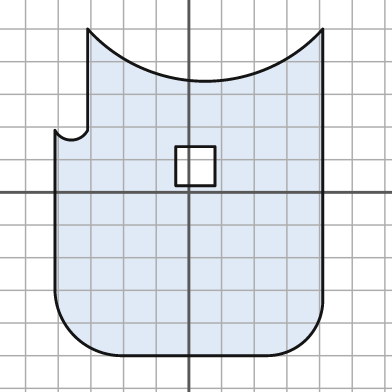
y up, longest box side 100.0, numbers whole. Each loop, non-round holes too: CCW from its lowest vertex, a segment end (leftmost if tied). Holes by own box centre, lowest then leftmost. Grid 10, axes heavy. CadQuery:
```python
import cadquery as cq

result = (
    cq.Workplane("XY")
    .moveTo(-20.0, -50.0)
    .lineTo(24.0, -50.0)
    .threePointArc((36.0, -45.0), (41.0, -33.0))
    .lineTo(41.0, 50.0)
    .threePointArc((5.0, 34.0), (-31.0, 50.0))
    .lineTo(-31.0, 19.0)
    .threePointArc((-36.0, 16.0), (-41.0, 19.0))
    .lineTo(-41.0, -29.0)
    .threePointArc((-35.0, -44.0), (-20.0, -50.0))
    .close()
    .moveTo(-4.0, 2.0)
    .lineTo(8.0, 2.0)
    .lineTo(8.0, 14.0)
    .lineTo(-4.0, 14.0)
    .close()
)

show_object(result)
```